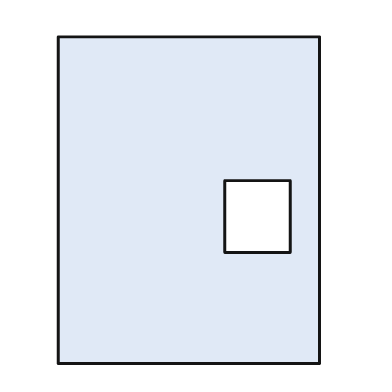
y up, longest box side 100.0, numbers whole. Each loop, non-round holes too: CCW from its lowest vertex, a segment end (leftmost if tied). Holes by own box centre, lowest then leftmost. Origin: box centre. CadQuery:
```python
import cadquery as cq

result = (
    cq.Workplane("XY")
    .moveTo(-40.0, -50.0)
    .lineTo(40.0, -50.0)
    .lineTo(40.0, 50.0)
    .lineTo(-40.0, 50.0)
    .close()
    .moveTo(11.0, -16.0)
    .lineTo(31.0, -16.0)
    .lineTo(31.0, 6.0)
    .lineTo(11.0, 6.0)
    .close()
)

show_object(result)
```